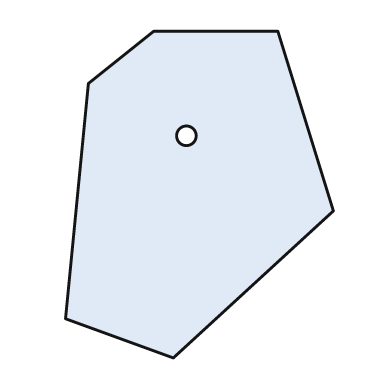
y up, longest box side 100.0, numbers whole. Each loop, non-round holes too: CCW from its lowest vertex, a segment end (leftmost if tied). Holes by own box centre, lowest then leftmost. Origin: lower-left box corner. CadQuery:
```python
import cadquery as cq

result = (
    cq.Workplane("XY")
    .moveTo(33.0, 0.0)
    .lineTo(82.0, 45.0)
    .lineTo(65.0, 100.0)
    .lineTo(27.0, 100.0)
    .lineTo(7.0, 84.0)
    .lineTo(0.0, 12.0)
    .close()
    .moveTo(37.0, 68.0)
    .circle(3.0)
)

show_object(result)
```